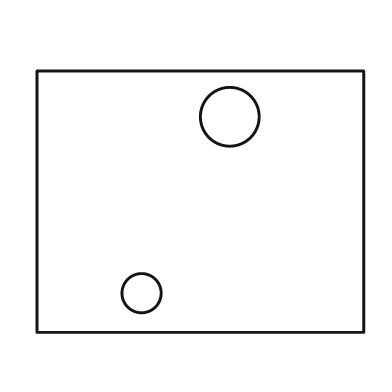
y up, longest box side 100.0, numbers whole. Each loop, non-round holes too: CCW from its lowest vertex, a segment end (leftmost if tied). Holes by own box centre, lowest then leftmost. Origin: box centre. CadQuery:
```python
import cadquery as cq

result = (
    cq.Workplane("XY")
    .moveTo(-50.0, -40.0)
    .lineTo(50.0, -40.0)
    .lineTo(50.0, 40.0)
    .lineTo(-50.0, 40.0)
    .close()
    .moveTo(-18.0, -28.0)
    .circle(6.0)
    .moveTo(9.0, 26.0)
    .circle(9.0)
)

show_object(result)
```